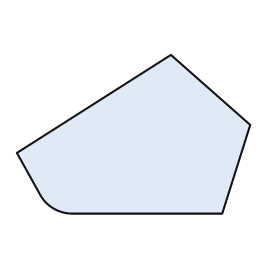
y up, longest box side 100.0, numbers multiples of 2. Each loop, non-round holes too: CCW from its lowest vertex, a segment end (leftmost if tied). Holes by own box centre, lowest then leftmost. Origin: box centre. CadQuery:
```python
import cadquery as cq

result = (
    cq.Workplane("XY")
    .moveTo(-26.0, -34.0)
    .lineTo(38.0, -34.0)
    .lineTo(50.0, 4.0)
    .lineTo(16.0, 34.0)
    .lineTo(-50.0, -8.0)
    .lineTo(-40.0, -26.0)
    .threePointArc((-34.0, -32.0), (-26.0, -34.0))
    .close()
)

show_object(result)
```